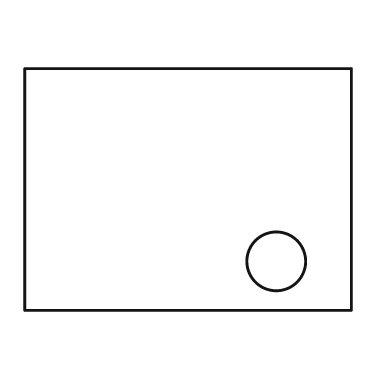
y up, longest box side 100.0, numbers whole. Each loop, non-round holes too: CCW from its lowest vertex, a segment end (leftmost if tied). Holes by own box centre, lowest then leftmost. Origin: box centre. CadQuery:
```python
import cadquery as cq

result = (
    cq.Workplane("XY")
    .moveTo(-50.0, -37.0)
    .lineTo(50.0, -37.0)
    .lineTo(50.0, 37.0)
    .lineTo(-50.0, 37.0)
    .close()
    .moveTo(27.0, -22.0)
    .circle(9.0)
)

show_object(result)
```